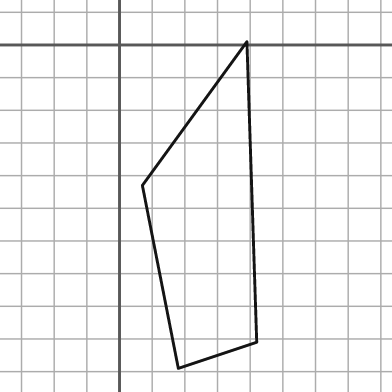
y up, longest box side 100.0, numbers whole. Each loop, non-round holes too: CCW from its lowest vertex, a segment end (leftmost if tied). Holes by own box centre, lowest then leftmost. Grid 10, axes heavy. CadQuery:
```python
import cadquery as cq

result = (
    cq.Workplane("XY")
    .moveTo(18.0, -99.0)
    .lineTo(42.0, -91.0)
    .lineTo(39.0, 1.0)
    .lineTo(7.0, -43.0)
    .close()
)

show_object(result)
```